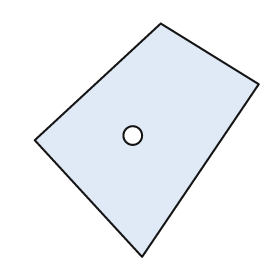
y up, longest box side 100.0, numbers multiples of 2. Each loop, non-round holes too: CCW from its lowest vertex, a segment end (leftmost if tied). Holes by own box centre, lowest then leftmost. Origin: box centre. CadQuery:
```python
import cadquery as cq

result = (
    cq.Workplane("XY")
    .moveTo(-2.0, -50.0)
    .lineTo(48.0, 24.0)
    .lineTo(6.0, 50.0)
    .lineTo(-48.0, 0.0)
    .close()
    .moveTo(-6.0, 2.0)
    .circle(4.0)
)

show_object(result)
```